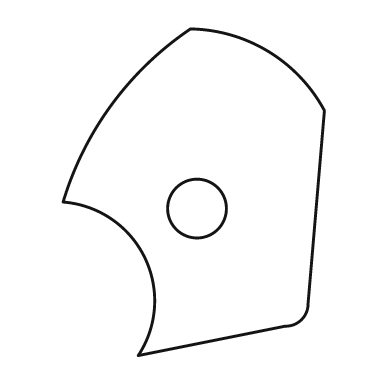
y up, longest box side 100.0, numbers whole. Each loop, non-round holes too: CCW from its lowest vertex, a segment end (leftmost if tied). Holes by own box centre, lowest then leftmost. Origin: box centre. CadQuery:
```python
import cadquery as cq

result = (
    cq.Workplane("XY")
    .moveTo(-17.0, -50.0)
    .lineTo(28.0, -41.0)
    .threePointArc((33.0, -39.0), (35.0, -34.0))
    .lineTo(40.0, 25.0)
    .threePointArc((23.0, 43.0), (-1.0, 50.0))
    .threePointArc((-25.0, 27.0), (-40.0, -3.0))
    .threePointArc((-15.0, -20.0), (-17.0, -50.0))
    .close()
    .moveTo(1.0, -5.0)
    .circle(9.0)
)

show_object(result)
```